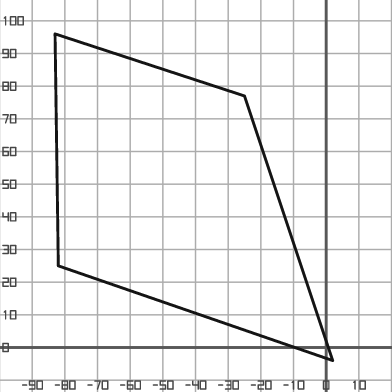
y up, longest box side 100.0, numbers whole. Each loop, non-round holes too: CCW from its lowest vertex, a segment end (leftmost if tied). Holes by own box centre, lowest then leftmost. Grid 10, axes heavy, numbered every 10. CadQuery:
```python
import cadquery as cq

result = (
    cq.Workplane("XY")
    .moveTo(2.0, -4.0)
    .lineTo(-25.0, 77.0)
    .lineTo(-83.0, 96.0)
    .lineTo(-82.0, 25.0)
    .close()
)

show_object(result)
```